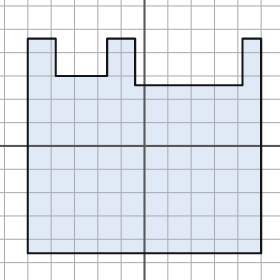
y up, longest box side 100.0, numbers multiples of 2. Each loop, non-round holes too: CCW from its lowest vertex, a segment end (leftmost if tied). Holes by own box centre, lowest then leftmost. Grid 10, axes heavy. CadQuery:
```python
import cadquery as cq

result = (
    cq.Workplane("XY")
    .moveTo(-50.0, -46.0)
    .lineTo(50.0, -46.0)
    .lineTo(50.0, 46.0)
    .lineTo(42.0, 46.0)
    .lineTo(42.0, 26.0)
    .lineTo(-4.0, 26.0)
    .lineTo(-4.0, 46.0)
    .lineTo(-16.0, 46.0)
    .lineTo(-16.0, 30.0)
    .lineTo(-38.0, 30.0)
    .lineTo(-38.0, 46.0)
    .lineTo(-50.0, 46.0)
    .close()
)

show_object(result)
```